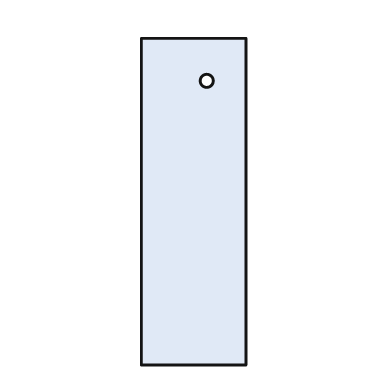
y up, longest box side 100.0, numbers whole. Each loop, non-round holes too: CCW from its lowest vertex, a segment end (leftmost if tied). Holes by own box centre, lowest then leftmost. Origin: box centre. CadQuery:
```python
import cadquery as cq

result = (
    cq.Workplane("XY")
    .moveTo(-16.0, -50.0)
    .lineTo(16.0, -50.0)
    .lineTo(16.0, 50.0)
    .lineTo(-16.0, 50.0)
    .close()
    .moveTo(4.0, 37.0)
    .circle(2.0)
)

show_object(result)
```